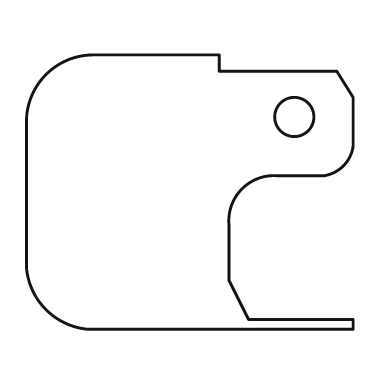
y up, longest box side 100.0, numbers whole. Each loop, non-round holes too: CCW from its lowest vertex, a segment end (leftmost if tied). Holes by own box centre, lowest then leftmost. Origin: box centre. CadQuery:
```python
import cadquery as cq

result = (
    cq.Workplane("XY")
    .moveTo(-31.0, -42.0)
    .lineTo(50.0, -42.0)
    .lineTo(50.0, -39.0)
    .lineTo(18.0, -39.0)
    .lineTo(12.0, -27.0)
    .lineTo(12.0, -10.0)
    .threePointArc((16.0, 1.0), (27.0, 5.0))
    .lineTo(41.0, 5.0)
    .threePointArc((47.0, 8.0), (50.0, 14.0))
    .lineTo(50.0, 29.0)
    .lineTo(45.0, 37.0)
    .lineTo(9.0, 37.0)
    .lineTo(9.0, 42.0)
    .lineTo(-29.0, 42.0)
    .threePointArc((-44.0, 36.0), (-50.0, 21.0))
    .lineTo(-50.0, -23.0)
    .threePointArc((-44.0, -36.0), (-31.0, -42.0))
    .close()
    .moveTo(32.0, 23.0)
    .circle(6.0)
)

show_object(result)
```